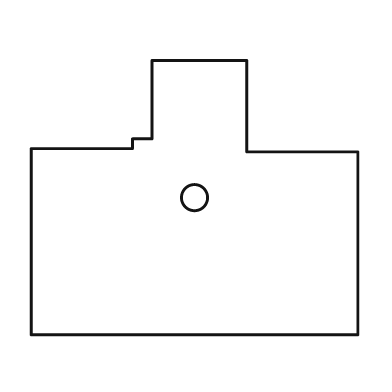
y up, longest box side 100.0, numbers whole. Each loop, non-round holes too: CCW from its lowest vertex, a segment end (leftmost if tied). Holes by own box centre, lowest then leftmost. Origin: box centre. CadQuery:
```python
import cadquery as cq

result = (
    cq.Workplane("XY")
    .moveTo(-50.0, -42.0)
    .lineTo(50.0, -42.0)
    .lineTo(50.0, 14.0)
    .lineTo(16.0, 14.0)
    .lineTo(16.0, 42.0)
    .lineTo(-13.0, 42.0)
    .lineTo(-13.0, 18.0)
    .lineTo(-19.0, 18.0)
    .lineTo(-19.0, 15.0)
    .lineTo(-50.0, 15.0)
    .close()
    .moveTo(0.0, 0.0)
    .circle(4.0)
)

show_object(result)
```